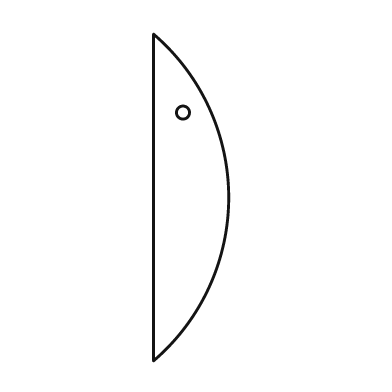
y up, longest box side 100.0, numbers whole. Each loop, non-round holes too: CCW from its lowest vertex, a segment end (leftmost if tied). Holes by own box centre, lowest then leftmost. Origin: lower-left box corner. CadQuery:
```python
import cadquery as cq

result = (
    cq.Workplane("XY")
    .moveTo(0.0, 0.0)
    .threePointArc((23.0, 50.0), (0.0, 100.0))
    .close()
    .moveTo(9.0, 76.0)
    .circle(2.0)
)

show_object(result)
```